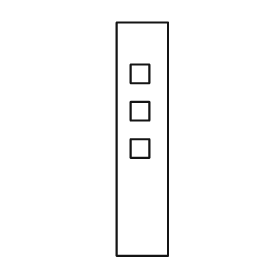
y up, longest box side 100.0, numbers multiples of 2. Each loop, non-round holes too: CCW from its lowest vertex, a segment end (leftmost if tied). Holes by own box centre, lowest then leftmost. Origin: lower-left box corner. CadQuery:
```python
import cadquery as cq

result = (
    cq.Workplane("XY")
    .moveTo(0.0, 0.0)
    .lineTo(22.0, 0.0)
    .lineTo(22.0, 100.0)
    .lineTo(0.0, 100.0)
    .close()
    .moveTo(6.0, 42.0)
    .lineTo(14.0, 42.0)
    .lineTo(14.0, 50.0)
    .lineTo(6.0, 50.0)
    .close()
    .moveTo(6.0, 58.0)
    .lineTo(14.0, 58.0)
    .lineTo(14.0, 66.0)
    .lineTo(6.0, 66.0)
    .close()
    .moveTo(6.0, 74.0)
    .lineTo(14.0, 74.0)
    .lineTo(14.0, 82.0)
    .lineTo(6.0, 82.0)
    .close()
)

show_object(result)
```